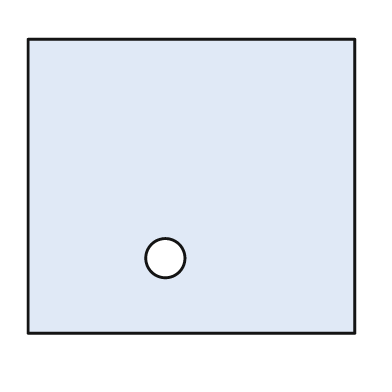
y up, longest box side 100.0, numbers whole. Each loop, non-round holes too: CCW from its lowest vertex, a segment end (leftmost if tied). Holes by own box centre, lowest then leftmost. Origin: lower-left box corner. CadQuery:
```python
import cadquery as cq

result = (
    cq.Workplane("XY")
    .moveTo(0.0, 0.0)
    .lineTo(100.0, 0.0)
    .lineTo(100.0, 90.0)
    .lineTo(0.0, 90.0)
    .close()
    .moveTo(42.0, 23.0)
    .circle(6.0)
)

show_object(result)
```